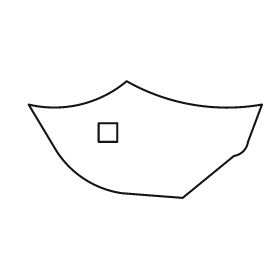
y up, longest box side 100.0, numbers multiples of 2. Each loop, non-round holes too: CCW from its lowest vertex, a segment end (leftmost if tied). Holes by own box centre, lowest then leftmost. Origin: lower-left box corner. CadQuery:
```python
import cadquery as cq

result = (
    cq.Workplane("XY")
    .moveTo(66.0, 0.0)
    .lineTo(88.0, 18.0)
    .threePointArc((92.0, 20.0), (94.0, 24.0))
    .lineTo(100.0, 40.0)
    .threePointArc((70.0, 40.0), (42.0, 50.0))
    .threePointArc((22.0, 40.0), (0.0, 40.0))
    .lineTo(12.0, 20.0)
    .threePointArc((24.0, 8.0), (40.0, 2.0))
    .close()
    .moveTo(30.0, 24.0)
    .lineTo(38.0, 24.0)
    .lineTo(38.0, 32.0)
    .lineTo(30.0, 32.0)
    .close()
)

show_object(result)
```